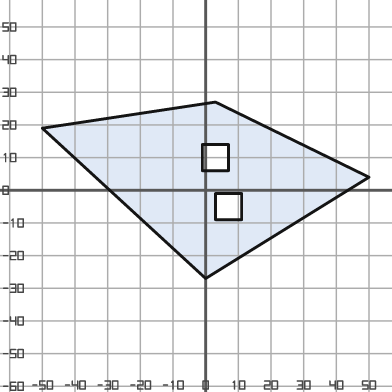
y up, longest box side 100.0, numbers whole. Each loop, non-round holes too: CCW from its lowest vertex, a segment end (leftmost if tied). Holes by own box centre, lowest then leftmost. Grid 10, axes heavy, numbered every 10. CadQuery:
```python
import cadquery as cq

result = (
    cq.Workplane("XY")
    .moveTo(0.0, -27.0)
    .lineTo(50.0, 4.0)
    .lineTo(3.0, 27.0)
    .lineTo(-50.0, 19.0)
    .close()
    .moveTo(3.0, -9.0)
    .lineTo(11.0, -9.0)
    .lineTo(11.0, -1.0)
    .lineTo(3.0, -1.0)
    .close()
    .moveTo(-1.0, 6.0)
    .lineTo(7.0, 6.0)
    .lineTo(7.0, 14.0)
    .lineTo(-1.0, 14.0)
    .close()
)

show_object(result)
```